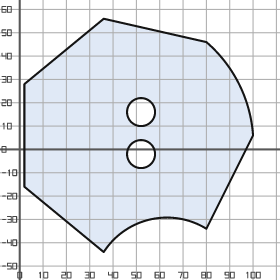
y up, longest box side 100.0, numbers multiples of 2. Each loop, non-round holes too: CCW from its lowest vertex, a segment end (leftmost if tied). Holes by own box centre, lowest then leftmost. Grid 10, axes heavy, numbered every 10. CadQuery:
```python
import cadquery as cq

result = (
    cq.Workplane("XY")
    .moveTo(36.0, -44.0)
    .threePointArc((56.0, -30.0), (80.0, -34.0))
    .lineTo(100.0, 6.0)
    .threePointArc((94.0, 28.0), (80.0, 46.0))
    .lineTo(36.0, 56.0)
    .lineTo(2.0, 28.0)
    .lineTo(2.0, -16.0)
    .close()
    .moveTo(52.0, -2.0)
    .circle(6.0)
    .moveTo(52.0, 16.0)
    .circle(6.0)
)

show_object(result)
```